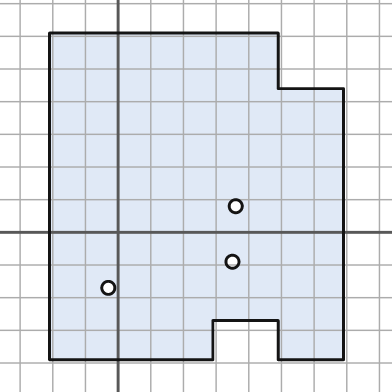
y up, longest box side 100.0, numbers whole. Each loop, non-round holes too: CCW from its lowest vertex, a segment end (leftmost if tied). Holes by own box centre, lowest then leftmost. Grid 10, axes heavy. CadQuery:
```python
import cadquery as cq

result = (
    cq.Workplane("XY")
    .moveTo(-21.0, -39.0)
    .lineTo(29.0, -39.0)
    .lineTo(29.0, -27.0)
    .lineTo(49.0, -27.0)
    .lineTo(49.0, -39.0)
    .lineTo(69.0, -39.0)
    .lineTo(69.0, 44.0)
    .lineTo(49.0, 44.0)
    .lineTo(49.0, 61.0)
    .lineTo(-21.0, 61.0)
    .close()
    .moveTo(-3.0, -17.0)
    .circle(2.0)
    .moveTo(35.0, -9.0)
    .circle(2.0)
    .moveTo(36.0, 8.0)
    .circle(2.0)
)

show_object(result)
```